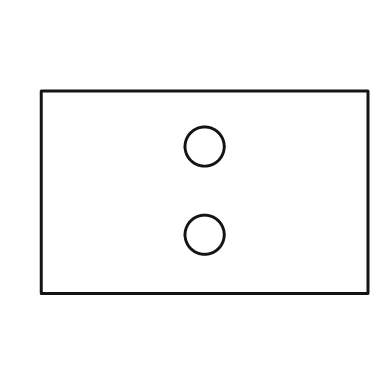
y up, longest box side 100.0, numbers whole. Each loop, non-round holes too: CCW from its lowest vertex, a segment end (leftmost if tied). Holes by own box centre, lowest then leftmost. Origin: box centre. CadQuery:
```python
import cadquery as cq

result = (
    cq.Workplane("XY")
    .moveTo(-50.0, -31.0)
    .lineTo(50.0, -31.0)
    .lineTo(50.0, 31.0)
    .lineTo(-50.0, 31.0)
    .close()
    .moveTo(0.0, -13.0)
    .circle(6.0)
    .moveTo(0.0, 14.0)
    .circle(6.0)
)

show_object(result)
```